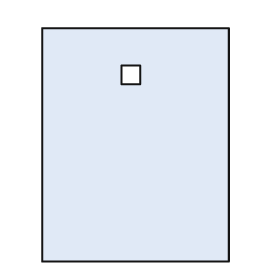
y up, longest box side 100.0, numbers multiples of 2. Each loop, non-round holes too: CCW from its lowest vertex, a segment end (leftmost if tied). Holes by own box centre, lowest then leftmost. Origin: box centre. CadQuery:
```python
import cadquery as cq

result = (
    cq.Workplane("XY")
    .moveTo(-40.0, -50.0)
    .lineTo(40.0, -50.0)
    .lineTo(40.0, 50.0)
    .lineTo(-40.0, 50.0)
    .close()
    .moveTo(-6.0, 26.0)
    .lineTo(2.0, 26.0)
    .lineTo(2.0, 34.0)
    .lineTo(-6.0, 34.0)
    .close()
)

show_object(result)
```